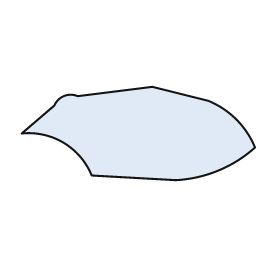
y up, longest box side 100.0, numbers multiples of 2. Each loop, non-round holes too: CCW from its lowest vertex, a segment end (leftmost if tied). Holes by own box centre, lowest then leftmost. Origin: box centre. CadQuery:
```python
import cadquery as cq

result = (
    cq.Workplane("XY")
    .moveTo(16.0, -20.0)
    .threePointArc((34.0, -16.0), (50.0, -6.0))
    .threePointArc((42.0, 6.0), (30.0, 14.0))
    .lineTo(6.0, 20.0)
    .lineTo(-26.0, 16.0)
    .threePointArc((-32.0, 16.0), (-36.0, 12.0))
    .lineTo(-50.0, 0.0)
    .threePointArc((-32.0, -4.0), (-20.0, -18.0))
    .close()
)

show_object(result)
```